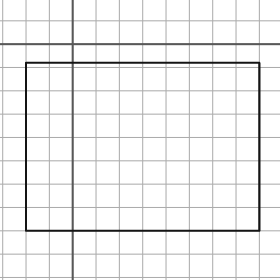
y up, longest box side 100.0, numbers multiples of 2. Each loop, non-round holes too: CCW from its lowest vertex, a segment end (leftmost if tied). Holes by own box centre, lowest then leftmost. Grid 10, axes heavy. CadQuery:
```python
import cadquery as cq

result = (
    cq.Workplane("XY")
    .moveTo(-20.0, -80.0)
    .lineTo(80.0, -80.0)
    .lineTo(80.0, -8.0)
    .lineTo(-20.0, -8.0)
    .close()
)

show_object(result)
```